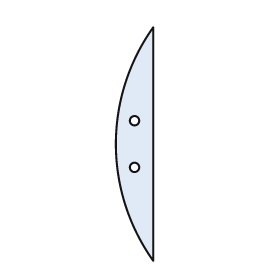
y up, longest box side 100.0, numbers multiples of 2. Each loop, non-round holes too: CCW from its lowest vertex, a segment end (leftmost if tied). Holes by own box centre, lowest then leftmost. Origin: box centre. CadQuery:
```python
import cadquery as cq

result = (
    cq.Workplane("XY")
    .moveTo(8.0, -50.0)
    .lineTo(8.0, 50.0)
    .threePointArc((-8.0, 0.0), (8.0, -50.0))
    .close()
    .moveTo(0.0, -10.0)
    .circle(2.0)
    .moveTo(0.0, 10.0)
    .circle(2.0)
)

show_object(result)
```